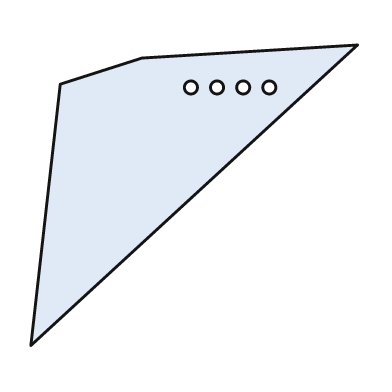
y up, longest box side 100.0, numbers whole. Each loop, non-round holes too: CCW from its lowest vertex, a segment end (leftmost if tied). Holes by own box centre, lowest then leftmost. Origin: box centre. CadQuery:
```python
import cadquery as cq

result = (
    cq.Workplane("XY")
    .moveTo(-50.0, -46.0)
    .lineTo(50.0, 46.0)
    .lineTo(-16.0, 42.0)
    .lineTo(-41.0, 34.0)
    .close()
    .moveTo(-1.0, 33.0)
    .circle(2.0)
    .moveTo(7.0, 33.0)
    .circle(2.0)
    .moveTo(15.0, 33.0)
    .circle(2.0)
    .moveTo(23.0, 33.0)
    .circle(2.0)
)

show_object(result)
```